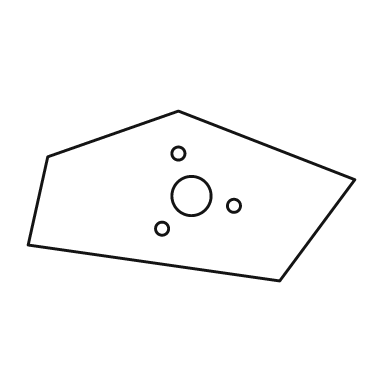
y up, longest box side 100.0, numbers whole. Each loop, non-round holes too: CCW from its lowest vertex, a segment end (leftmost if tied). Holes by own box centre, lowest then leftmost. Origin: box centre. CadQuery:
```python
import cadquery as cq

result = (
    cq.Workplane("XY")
    .moveTo(27.0, -26.0)
    .lineTo(50.0, 5.0)
    .lineTo(-4.0, 26.0)
    .lineTo(-44.0, 12.0)
    .lineTo(-50.0, -15.0)
    .close()
    .moveTo(-9.0, -10.0)
    .circle(2.0)
    .moveTo(13.0, -3.0)
    .circle(2.0)
    .moveTo(0.0, 0.0)
    .circle(6.0)
    .moveTo(-4.0, 13.0)
    .circle(2.0)
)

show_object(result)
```